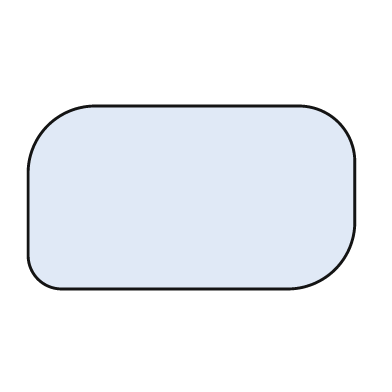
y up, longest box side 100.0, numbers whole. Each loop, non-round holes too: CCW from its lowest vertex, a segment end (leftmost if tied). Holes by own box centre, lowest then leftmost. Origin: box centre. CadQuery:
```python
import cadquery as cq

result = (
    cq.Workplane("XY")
    .moveTo(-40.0, -28.0)
    .lineTo(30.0, -28.0)
    .threePointArc((44.0, -22.0), (50.0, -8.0))
    .lineTo(50.0, 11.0)
    .threePointArc((45.0, 23.0), (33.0, 28.0))
    .lineTo(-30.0, 28.0)
    .threePointArc((-44.0, 22.0), (-50.0, 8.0))
    .lineTo(-50.0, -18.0)
    .threePointArc((-47.0, -25.0), (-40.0, -28.0))
    .close()
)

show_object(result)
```